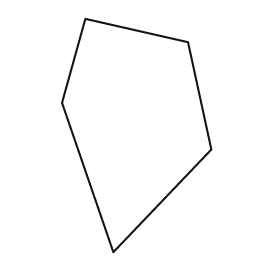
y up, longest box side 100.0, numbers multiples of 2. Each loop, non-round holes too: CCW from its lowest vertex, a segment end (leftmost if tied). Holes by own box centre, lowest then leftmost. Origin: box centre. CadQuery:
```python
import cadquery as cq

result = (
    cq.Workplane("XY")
    .moveTo(-10.0, -50.0)
    .lineTo(32.0, -6.0)
    .lineTo(22.0, 40.0)
    .lineTo(-22.0, 50.0)
    .lineTo(-32.0, 14.0)
    .close()
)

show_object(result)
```